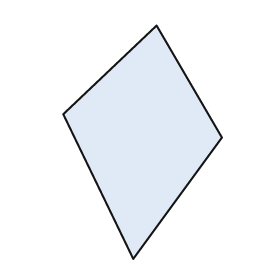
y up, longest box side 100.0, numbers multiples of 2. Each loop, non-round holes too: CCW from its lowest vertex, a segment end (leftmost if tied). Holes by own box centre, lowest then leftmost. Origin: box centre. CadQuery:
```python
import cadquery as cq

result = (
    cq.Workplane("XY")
    .moveTo(-4.0, -50.0)
    .lineTo(34.0, 2.0)
    .lineTo(6.0, 50.0)
    .lineTo(-34.0, 12.0)
    .close()
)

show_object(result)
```